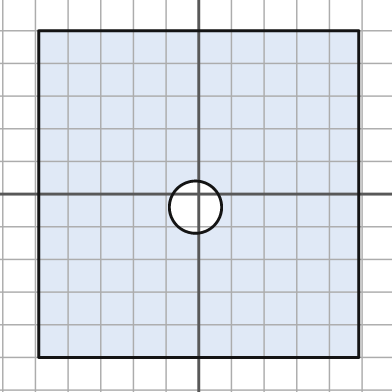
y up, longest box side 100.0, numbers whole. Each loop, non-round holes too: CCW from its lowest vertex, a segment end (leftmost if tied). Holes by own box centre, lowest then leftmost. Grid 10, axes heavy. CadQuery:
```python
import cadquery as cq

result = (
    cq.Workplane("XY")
    .moveTo(-49.0, -50.0)
    .lineTo(49.0, -50.0)
    .lineTo(49.0, 50.0)
    .lineTo(-49.0, 50.0)
    .close()
    .moveTo(-1.0, -4.0)
    .circle(8.0)
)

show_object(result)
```